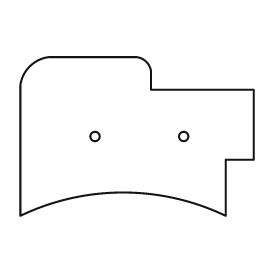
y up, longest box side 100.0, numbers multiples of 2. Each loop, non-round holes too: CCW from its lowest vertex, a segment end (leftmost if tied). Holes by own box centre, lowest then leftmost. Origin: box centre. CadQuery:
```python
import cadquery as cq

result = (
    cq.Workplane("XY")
    .moveTo(-50.0, -34.0)
    .threePointArc((-6.0, -24.0), (38.0, -34.0))
    .lineTo(38.0, -10.0)
    .lineTo(50.0, -10.0)
    .lineTo(50.0, 20.0)
    .lineTo(6.0, 20.0)
    .lineTo(6.0, 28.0)
    .threePointArc((4.0, 32.0), (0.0, 34.0))
    .lineTo(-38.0, 34.0)
    .threePointArc((-46.0, 30.0), (-50.0, 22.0))
    .close()
    .moveTo(-18.0, 0.0)
    .circle(2.0)
    .moveTo(20.0, 0.0)
    .circle(2.0)
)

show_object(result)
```